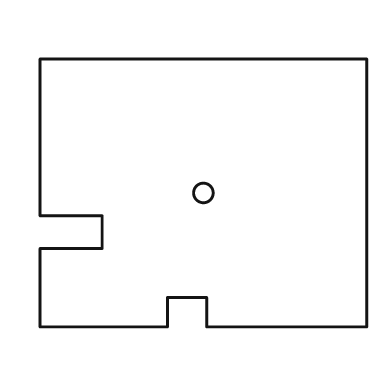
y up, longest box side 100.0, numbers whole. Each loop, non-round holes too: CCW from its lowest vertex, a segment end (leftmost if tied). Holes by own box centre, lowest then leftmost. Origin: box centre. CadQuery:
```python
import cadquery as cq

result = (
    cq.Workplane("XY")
    .moveTo(-50.0, -41.0)
    .lineTo(-11.0, -41.0)
    .lineTo(-11.0, -32.0)
    .lineTo(1.0, -32.0)
    .lineTo(1.0, -41.0)
    .lineTo(50.0, -41.0)
    .lineTo(50.0, 41.0)
    .lineTo(-50.0, 41.0)
    .lineTo(-50.0, -7.0)
    .lineTo(-31.0, -7.0)
    .lineTo(-31.0, -17.0)
    .lineTo(-50.0, -17.0)
    .close()
    .moveTo(0.0, 0.0)
    .circle(3.0)
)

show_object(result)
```